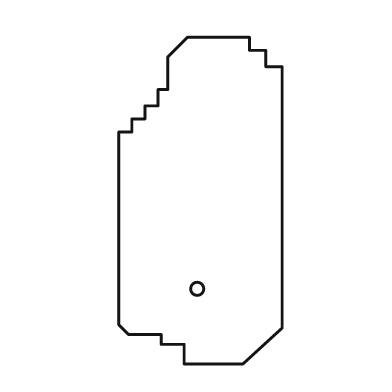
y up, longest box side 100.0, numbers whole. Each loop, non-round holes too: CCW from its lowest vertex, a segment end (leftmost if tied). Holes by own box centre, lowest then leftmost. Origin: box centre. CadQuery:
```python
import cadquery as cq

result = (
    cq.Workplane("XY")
    .moveTo(-5.0, -50.0)
    .lineTo(13.0, -50.0)
    .lineTo(25.0, -39.0)
    .lineTo(25.0, 41.0)
    .lineTo(20.0, 41.0)
    .lineTo(20.0, 46.0)
    .lineTo(15.0, 46.0)
    .lineTo(15.0, 50.0)
    .lineTo(-4.0, 50.0)
    .lineTo(-10.0, 44.0)
    .lineTo(-10.0, 34.0)
    .lineTo(-13.0, 34.0)
    .lineTo(-13.0, 29.0)
    .lineTo(-17.0, 29.0)
    .lineTo(-17.0, 25.0)
    .lineTo(-21.0, 25.0)
    .lineTo(-21.0, 21.0)
    .lineTo(-25.0, 21.0)
    .lineTo(-25.0, -38.0)
    .lineTo(-22.0, -41.0)
    .lineTo(-12.0, -41.0)
    .lineTo(-12.0, -44.0)
    .lineTo(-5.0, -44.0)
    .close()
    .moveTo(-1.0, -27.0)
    .circle(2.0)
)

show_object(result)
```